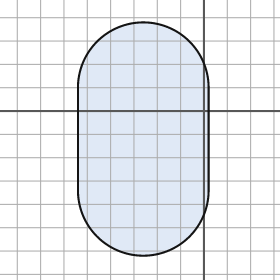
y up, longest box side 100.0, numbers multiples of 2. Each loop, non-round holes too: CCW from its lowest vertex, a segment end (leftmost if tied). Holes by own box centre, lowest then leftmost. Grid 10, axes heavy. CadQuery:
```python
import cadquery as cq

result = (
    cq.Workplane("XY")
    .moveTo(-54.0, -34.0)
    .threePointArc((-26.0, -62.0), (2.0, -34.0))
    .lineTo(2.0, 10.0)
    .threePointArc((-26.0, 38.0), (-54.0, 10.0))
    .close()
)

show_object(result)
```